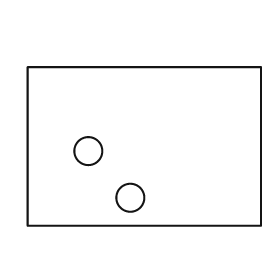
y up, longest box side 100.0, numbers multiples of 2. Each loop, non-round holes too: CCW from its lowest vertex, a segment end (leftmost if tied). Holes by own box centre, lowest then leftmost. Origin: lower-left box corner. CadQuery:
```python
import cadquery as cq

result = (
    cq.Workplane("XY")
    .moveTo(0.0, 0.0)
    .lineTo(100.0, 0.0)
    .lineTo(100.0, 68.0)
    .lineTo(0.0, 68.0)
    .close()
    .moveTo(44.0, 12.0)
    .circle(6.0)
    .moveTo(26.0, 32.0)
    .circle(6.0)
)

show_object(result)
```